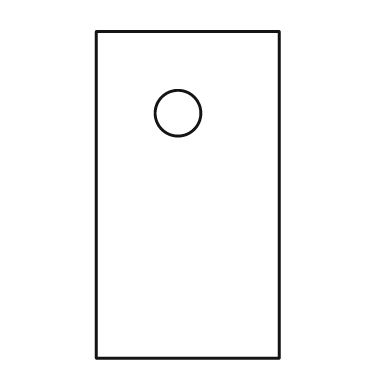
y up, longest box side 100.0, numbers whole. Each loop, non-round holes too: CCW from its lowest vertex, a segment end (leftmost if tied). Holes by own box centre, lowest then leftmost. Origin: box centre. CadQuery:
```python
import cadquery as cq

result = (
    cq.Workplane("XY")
    .moveTo(-28.0, -50.0)
    .lineTo(28.0, -50.0)
    .lineTo(28.0, 50.0)
    .lineTo(-28.0, 50.0)
    .close()
    .moveTo(-3.0, 25.0)
    .circle(7.0)
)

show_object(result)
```